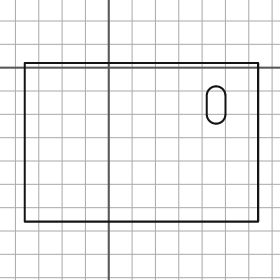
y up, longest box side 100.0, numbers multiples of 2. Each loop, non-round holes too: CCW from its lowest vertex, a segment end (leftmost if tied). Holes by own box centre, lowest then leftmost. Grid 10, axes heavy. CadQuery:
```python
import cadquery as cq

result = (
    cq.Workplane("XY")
    .moveTo(-36.0, -66.0)
    .lineTo(64.0, -66.0)
    .lineTo(64.0, 2.0)
    .lineTo(-36.0, 2.0)
    .close()
    .moveTo(42.0, -20.0)
    .threePointArc((46.0, -24.0), (50.0, -20.0))
    .lineTo(50.0, -12.0)
    .threePointArc((46.0, -8.0), (42.0, -12.0))
    .close()
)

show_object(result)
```